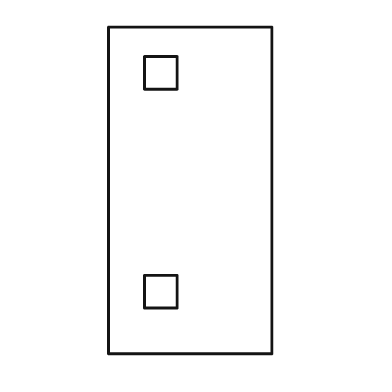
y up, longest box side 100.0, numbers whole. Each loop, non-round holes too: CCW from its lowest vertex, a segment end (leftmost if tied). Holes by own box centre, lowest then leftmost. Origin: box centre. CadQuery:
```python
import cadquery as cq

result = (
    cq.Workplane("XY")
    .moveTo(-25.0, -50.0)
    .lineTo(25.0, -50.0)
    .lineTo(25.0, 50.0)
    .lineTo(-25.0, 50.0)
    .close()
    .moveTo(-14.0, -36.0)
    .lineTo(-4.0, -36.0)
    .lineTo(-4.0, -26.0)
    .lineTo(-14.0, -26.0)
    .close()
    .moveTo(-14.0, 31.0)
    .lineTo(-4.0, 31.0)
    .lineTo(-4.0, 41.0)
    .lineTo(-14.0, 41.0)
    .close()
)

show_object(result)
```